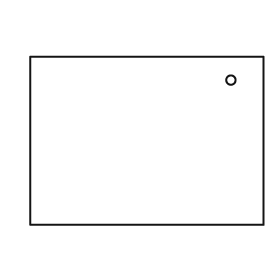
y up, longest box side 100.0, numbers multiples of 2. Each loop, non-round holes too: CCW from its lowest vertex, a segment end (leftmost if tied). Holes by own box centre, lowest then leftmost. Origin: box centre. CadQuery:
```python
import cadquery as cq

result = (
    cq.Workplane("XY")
    .moveTo(-50.0, -36.0)
    .lineTo(50.0, -36.0)
    .lineTo(50.0, 36.0)
    .lineTo(-50.0, 36.0)
    .close()
    .moveTo(36.0, 26.0)
    .circle(2.0)
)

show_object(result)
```